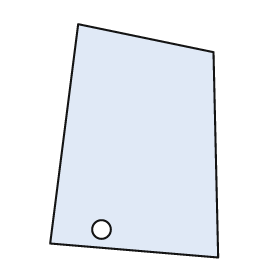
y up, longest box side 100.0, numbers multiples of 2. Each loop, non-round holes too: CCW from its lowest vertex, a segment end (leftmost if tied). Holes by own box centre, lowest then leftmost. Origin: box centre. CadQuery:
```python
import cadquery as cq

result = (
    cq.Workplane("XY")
    .moveTo(36.0, -50.0)
    .lineTo(34.0, 38.0)
    .lineTo(-24.0, 50.0)
    .lineTo(-36.0, -44.0)
    .close()
    .moveTo(-14.0, -38.0)
    .circle(4.0)
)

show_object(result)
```